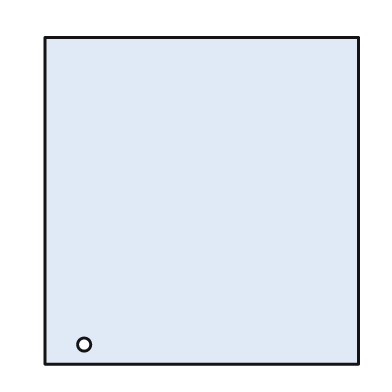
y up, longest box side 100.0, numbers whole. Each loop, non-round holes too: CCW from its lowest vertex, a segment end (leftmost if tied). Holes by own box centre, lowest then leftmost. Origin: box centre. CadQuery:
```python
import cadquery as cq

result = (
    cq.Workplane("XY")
    .moveTo(-48.0, -50.0)
    .lineTo(48.0, -50.0)
    .lineTo(48.0, 50.0)
    .lineTo(-48.0, 50.0)
    .close()
    .moveTo(-36.0, -44.0)
    .circle(2.0)
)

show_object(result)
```